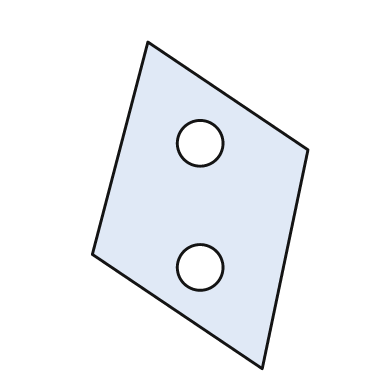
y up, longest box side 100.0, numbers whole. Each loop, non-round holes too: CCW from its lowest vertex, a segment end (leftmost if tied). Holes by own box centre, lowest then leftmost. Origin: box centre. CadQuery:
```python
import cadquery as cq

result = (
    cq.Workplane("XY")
    .moveTo(19.0, -50.0)
    .lineTo(33.0, 17.0)
    .lineTo(-16.0, 50.0)
    .lineTo(-33.0, -15.0)
    .close()
    .moveTo(0.0, -19.0)
    .circle(7.0)
    .moveTo(0.0, 19.0)
    .circle(7.0)
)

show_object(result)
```